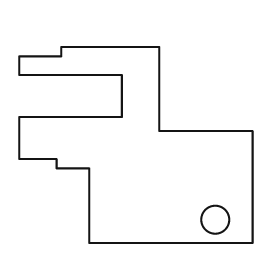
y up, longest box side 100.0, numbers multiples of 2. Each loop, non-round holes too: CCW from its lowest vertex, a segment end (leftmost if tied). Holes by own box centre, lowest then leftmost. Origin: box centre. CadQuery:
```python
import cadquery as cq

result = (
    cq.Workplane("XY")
    .moveTo(-20.0, -42.0)
    .lineTo(50.0, -42.0)
    .lineTo(50.0, 6.0)
    .lineTo(10.0, 6.0)
    .lineTo(10.0, 42.0)
    .lineTo(-32.0, 42.0)
    .lineTo(-32.0, 38.0)
    .lineTo(-50.0, 38.0)
    .lineTo(-50.0, 30.0)
    .lineTo(-6.0, 30.0)
    .lineTo(-6.0, 12.0)
    .lineTo(-50.0, 12.0)
    .lineTo(-50.0, -6.0)
    .lineTo(-34.0, -6.0)
    .lineTo(-34.0, -10.0)
    .lineTo(-20.0, -10.0)
    .close()
    .moveTo(34.0, -32.0)
    .circle(6.0)
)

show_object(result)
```